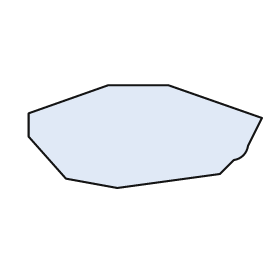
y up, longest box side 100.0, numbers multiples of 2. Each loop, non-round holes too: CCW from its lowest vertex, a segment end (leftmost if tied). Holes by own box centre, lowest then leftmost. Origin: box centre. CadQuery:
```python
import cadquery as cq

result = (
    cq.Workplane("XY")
    .moveTo(-12.0, -22.0)
    .lineTo(32.0, -16.0)
    .lineTo(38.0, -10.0)
    .threePointArc((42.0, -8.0), (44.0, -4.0))
    .lineTo(50.0, 8.0)
    .lineTo(10.0, 22.0)
    .lineTo(-16.0, 22.0)
    .lineTo(-50.0, 10.0)
    .lineTo(-50.0, 0.0)
    .lineTo(-34.0, -18.0)
    .close()
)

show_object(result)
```